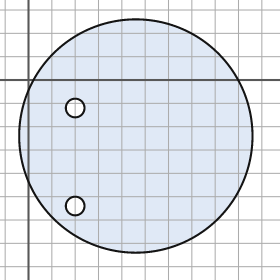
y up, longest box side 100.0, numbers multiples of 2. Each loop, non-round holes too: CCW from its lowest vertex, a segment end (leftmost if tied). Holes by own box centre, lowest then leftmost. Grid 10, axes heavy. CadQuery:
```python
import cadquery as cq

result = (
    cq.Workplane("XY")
    .moveTo(46.0, -24.0)
    .circle(50.0)
    .moveTo(20.0, -54.0)
    .circle(4.0)
    .moveTo(20.0, -12.0)
    .circle(4.0)
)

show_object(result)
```